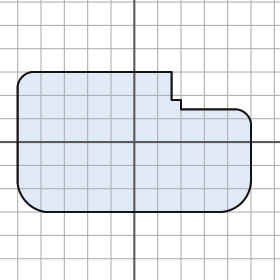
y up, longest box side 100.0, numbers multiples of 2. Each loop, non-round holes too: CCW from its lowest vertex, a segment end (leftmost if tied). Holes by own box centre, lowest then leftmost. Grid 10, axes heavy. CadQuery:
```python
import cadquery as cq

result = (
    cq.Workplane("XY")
    .moveTo(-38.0, -30.0)
    .lineTo(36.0, -30.0)
    .threePointArc((46.0, -26.0), (50.0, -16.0))
    .lineTo(50.0, 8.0)
    .threePointArc((48.0, 12.0), (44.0, 14.0))
    .lineTo(20.0, 14.0)
    .lineTo(20.0, 18.0)
    .lineTo(16.0, 18.0)
    .lineTo(16.0, 30.0)
    .lineTo(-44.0, 30.0)
    .threePointArc((-48.0, 28.0), (-50.0, 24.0))
    .lineTo(-50.0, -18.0)
    .threePointArc((-46.0, -26.0), (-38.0, -30.0))
    .close()
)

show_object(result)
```